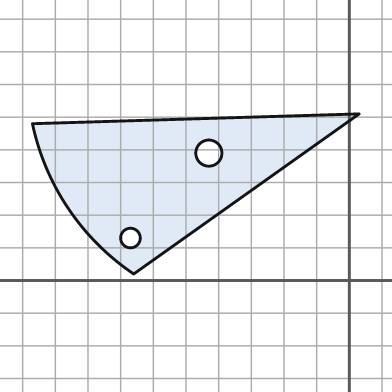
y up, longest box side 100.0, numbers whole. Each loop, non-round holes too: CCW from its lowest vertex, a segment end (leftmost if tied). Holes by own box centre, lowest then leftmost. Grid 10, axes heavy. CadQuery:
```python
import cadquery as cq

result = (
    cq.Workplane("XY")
    .moveTo(-66.0, 2.0)
    .lineTo(3.0, 51.0)
    .lineTo(-97.0, 48.0)
    .threePointArc((-86.0, 22.0), (-66.0, 2.0))
    .close()
    .moveTo(-67.0, 13.0)
    .circle(3.0)
    .moveTo(-43.0, 39.0)
    .circle(4.0)
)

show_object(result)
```